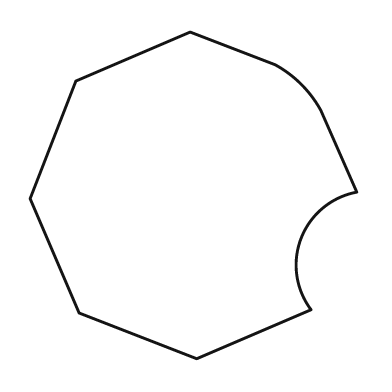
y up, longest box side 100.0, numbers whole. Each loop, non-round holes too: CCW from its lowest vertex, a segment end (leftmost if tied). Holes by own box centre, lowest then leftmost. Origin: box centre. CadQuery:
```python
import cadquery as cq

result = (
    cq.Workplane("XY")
    .moveTo(1.0, -50.0)
    .lineTo(36.0, -35.0)
    .threePointArc((33.0, -13.0), (50.0, 1.0))
    .lineTo(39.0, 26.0)
    .threePointArc((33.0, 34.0), (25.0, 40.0))
    .lineTo(-1.0, 50.0)
    .lineTo(-36.0, 35.0)
    .lineTo(-50.0, -1.0)
    .lineTo(-35.0, -36.0)
    .close()
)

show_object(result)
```